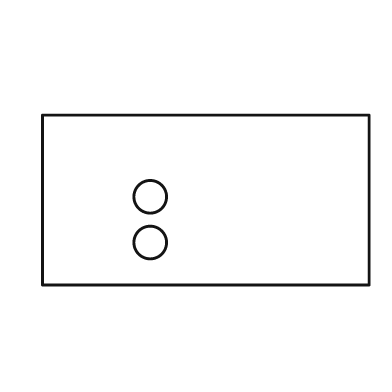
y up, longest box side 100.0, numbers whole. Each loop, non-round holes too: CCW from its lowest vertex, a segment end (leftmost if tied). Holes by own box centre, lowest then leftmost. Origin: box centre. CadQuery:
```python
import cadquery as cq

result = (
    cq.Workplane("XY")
    .moveTo(-50.0, -26.0)
    .lineTo(50.0, -26.0)
    .lineTo(50.0, 26.0)
    .lineTo(-50.0, 26.0)
    .close()
    .moveTo(-17.0, -13.0)
    .circle(5.0)
    .moveTo(-17.0, 1.0)
    .circle(5.0)
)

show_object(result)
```